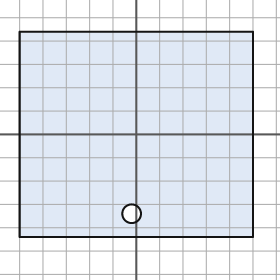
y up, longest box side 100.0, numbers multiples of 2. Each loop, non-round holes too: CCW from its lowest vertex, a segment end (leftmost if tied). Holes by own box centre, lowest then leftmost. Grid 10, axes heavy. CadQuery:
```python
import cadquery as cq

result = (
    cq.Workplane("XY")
    .moveTo(-50.0, -44.0)
    .lineTo(50.0, -44.0)
    .lineTo(50.0, 44.0)
    .lineTo(-50.0, 44.0)
    .close()
    .moveTo(-2.0, -34.0)
    .circle(4.0)
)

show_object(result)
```